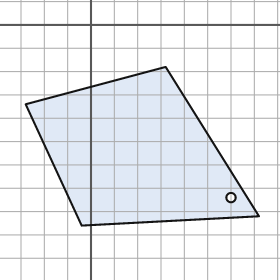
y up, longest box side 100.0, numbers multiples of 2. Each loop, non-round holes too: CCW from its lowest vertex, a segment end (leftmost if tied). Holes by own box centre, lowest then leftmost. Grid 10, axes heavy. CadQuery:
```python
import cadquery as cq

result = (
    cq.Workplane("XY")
    .moveTo(-4.0, -86.0)
    .lineTo(72.0, -82.0)
    .lineTo(32.0, -18.0)
    .lineTo(-28.0, -34.0)
    .close()
    .moveTo(60.0, -74.0)
    .circle(2.0)
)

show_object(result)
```